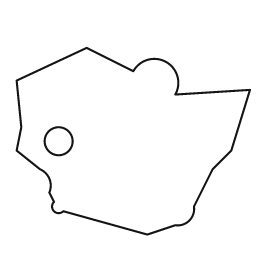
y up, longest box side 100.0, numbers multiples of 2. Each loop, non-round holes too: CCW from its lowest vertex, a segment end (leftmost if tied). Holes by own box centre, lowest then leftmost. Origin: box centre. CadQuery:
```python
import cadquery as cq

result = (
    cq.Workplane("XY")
    .moveTo(6.0, -40.0)
    .lineTo(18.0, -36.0)
    .threePointArc((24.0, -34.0), (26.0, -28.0))
    .lineTo(34.0, -12.0)
    .lineTo(42.0, -4.0)
    .lineTo(50.0, 22.0)
    .lineTo(18.0, 20.0)
    .threePointArc((14.0, 34.0), (0.0, 30.0))
    .lineTo(-20.0, 40.0)
    .lineTo(-50.0, 26.0)
    .lineTo(-48.0, 6.0)
    .lineTo(-50.0, -4.0)
    .lineTo(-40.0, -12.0)
    .threePointArc((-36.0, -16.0), (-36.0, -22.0))
    .lineTo(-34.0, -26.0)
    .threePointArc((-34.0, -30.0), (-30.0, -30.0))
    .close()
    .moveTo(-32.0, 0.0)
    .circle(6.0)
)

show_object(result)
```